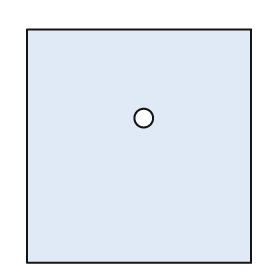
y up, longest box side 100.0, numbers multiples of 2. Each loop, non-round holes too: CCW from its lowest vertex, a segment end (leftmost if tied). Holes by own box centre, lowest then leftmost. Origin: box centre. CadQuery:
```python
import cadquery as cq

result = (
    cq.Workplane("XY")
    .moveTo(-48.0, -50.0)
    .lineTo(48.0, -50.0)
    .lineTo(48.0, 50.0)
    .lineTo(-48.0, 50.0)
    .close()
    .moveTo(2.0, 12.0)
    .circle(4.0)
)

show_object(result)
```